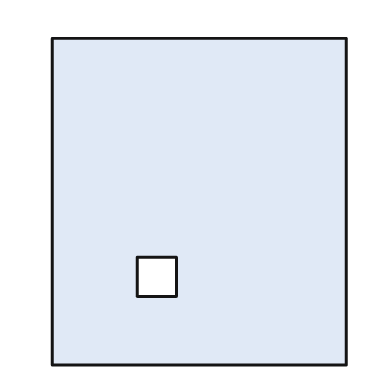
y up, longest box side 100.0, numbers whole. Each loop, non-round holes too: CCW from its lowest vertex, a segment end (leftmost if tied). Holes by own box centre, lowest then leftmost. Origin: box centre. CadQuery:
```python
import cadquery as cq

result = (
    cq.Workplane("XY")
    .moveTo(-45.0, -50.0)
    .lineTo(45.0, -50.0)
    .lineTo(45.0, 50.0)
    .lineTo(-45.0, 50.0)
    .close()
    .moveTo(-19.0, -29.0)
    .lineTo(-7.0, -29.0)
    .lineTo(-7.0, -17.0)
    .lineTo(-19.0, -17.0)
    .close()
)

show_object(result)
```